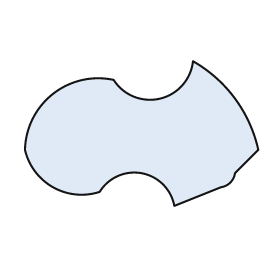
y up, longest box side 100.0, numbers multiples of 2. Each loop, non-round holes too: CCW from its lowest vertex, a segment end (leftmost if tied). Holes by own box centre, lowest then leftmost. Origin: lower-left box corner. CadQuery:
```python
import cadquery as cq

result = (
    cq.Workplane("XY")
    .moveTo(64.0, 0.0)
    .lineTo(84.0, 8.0)
    .threePointArc((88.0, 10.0), (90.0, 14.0))
    .lineTo(100.0, 24.0)
    .threePointArc((90.0, 46.0), (72.0, 62.0))
    .threePointArc((58.0, 46.0), (38.0, 54.0))
    .threePointArc((12.0, 48.0), (0.0, 24.0))
    .threePointArc((12.0, 8.0), (32.0, 6.0))
    .threePointArc((50.0, 14.0), (64.0, 0.0))
    .close()
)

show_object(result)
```